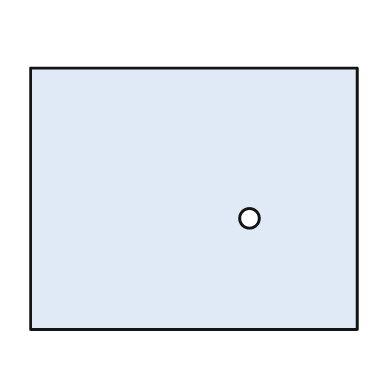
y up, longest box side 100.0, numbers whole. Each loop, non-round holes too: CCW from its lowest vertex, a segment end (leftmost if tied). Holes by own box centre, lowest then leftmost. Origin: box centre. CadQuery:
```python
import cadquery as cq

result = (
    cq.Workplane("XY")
    .moveTo(-50.0, -40.0)
    .lineTo(50.0, -40.0)
    .lineTo(50.0, 40.0)
    .lineTo(-50.0, 40.0)
    .close()
    .moveTo(17.0, -6.0)
    .circle(3.0)
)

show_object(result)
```